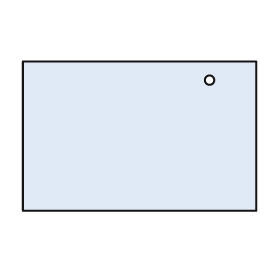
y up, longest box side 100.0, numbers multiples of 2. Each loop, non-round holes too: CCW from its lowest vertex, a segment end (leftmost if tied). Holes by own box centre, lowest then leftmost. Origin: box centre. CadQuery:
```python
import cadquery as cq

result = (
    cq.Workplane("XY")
    .moveTo(-50.0, -32.0)
    .lineTo(50.0, -32.0)
    .lineTo(50.0, 32.0)
    .lineTo(-50.0, 32.0)
    .close()
    .moveTo(30.0, 24.0)
    .circle(2.0)
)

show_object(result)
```